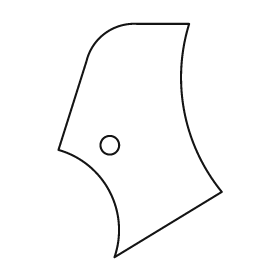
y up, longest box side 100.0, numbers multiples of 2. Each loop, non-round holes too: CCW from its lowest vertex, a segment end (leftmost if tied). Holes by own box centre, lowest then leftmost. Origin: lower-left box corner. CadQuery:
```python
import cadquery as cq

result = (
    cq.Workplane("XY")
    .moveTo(24.0, 0.0)
    .lineTo(70.0, 28.0)
    .threePointArc((54.0, 62.0), (56.0, 100.0))
    .lineTo(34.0, 100.0)
    .threePointArc((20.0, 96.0), (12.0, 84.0))
    .lineTo(0.0, 46.0)
    .threePointArc((22.0, 28.0), (24.0, 0.0))
    .close()
    .moveTo(22.0, 48.0)
    .circle(4.0)
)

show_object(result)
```